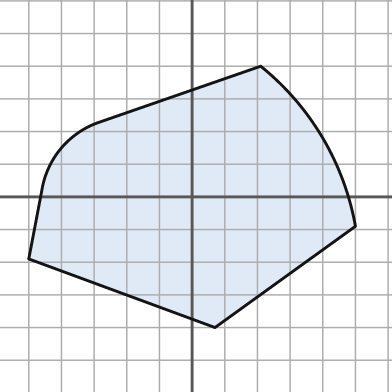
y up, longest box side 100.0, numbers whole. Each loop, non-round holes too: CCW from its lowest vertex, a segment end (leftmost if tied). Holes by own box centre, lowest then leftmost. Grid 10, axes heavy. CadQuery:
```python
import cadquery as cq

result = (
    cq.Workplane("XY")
    .moveTo(7.0, -40.0)
    .lineTo(50.0, -9.0)
    .threePointArc((40.0, 18.0), (21.0, 40.0))
    .lineTo(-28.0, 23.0)
    .threePointArc((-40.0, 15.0), (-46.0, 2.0))
    .lineTo(-50.0, -19.0)
    .close()
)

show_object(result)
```